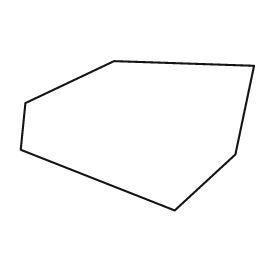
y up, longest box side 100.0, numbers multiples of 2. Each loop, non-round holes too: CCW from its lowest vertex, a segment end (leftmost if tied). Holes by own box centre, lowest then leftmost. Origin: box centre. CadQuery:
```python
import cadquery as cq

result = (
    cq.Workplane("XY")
    .moveTo(16.0, -32.0)
    .lineTo(42.0, -8.0)
    .lineTo(50.0, 30.0)
    .lineTo(-10.0, 32.0)
    .lineTo(-48.0, 14.0)
    .lineTo(-50.0, -6.0)
    .close()
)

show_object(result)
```